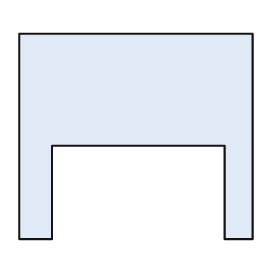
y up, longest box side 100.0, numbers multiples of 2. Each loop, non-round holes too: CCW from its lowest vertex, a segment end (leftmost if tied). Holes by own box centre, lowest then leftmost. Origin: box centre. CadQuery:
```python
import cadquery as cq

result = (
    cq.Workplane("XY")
    .moveTo(-50.0, -44.0)
    .lineTo(-36.0, -44.0)
    .lineTo(-36.0, -4.0)
    .lineTo(38.0, -4.0)
    .lineTo(38.0, -44.0)
    .lineTo(50.0, -44.0)
    .lineTo(50.0, 44.0)
    .lineTo(-50.0, 44.0)
    .close()
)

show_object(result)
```